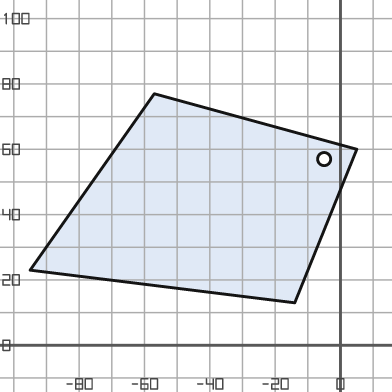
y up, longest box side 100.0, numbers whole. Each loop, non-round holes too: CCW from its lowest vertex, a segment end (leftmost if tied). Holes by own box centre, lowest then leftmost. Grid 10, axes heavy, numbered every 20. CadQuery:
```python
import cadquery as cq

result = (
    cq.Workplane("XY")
    .moveTo(-14.0, 13.0)
    .lineTo(5.0, 60.0)
    .lineTo(-57.0, 77.0)
    .lineTo(-95.0, 23.0)
    .close()
    .moveTo(-5.0, 57.0)
    .circle(2.0)
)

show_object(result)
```